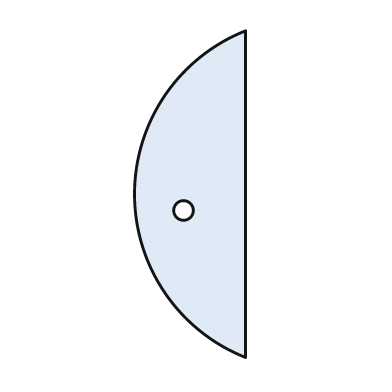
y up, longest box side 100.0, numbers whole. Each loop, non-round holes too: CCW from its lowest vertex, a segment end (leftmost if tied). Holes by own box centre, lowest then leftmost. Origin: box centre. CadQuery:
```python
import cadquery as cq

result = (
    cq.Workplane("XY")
    .moveTo(17.0, -50.0)
    .lineTo(17.0, 50.0)
    .threePointArc((-17.0, 0.0), (17.0, -50.0))
    .close()
    .moveTo(-2.0, -5.0)
    .circle(3.0)
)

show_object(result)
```